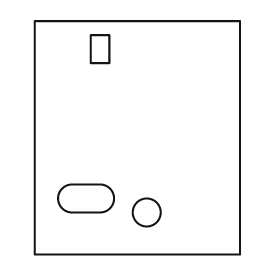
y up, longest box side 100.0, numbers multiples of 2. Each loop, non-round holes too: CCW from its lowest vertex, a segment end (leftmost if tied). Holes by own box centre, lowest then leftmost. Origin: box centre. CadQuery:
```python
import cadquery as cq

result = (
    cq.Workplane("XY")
    .moveTo(-44.0, -50.0)
    .lineTo(44.0, -50.0)
    .lineTo(44.0, 50.0)
    .lineTo(-44.0, 50.0)
    .close()
    .moveTo(4.0, -32.0)
    .circle(6.0)
    .moveTo(-28.0, -32.0)
    .lineTo(-16.0, -32.0)
    .threePointArc((-10.0, -26.0), (-16.0, -20.0))
    .lineTo(-28.0, -20.0)
    .threePointArc((-34.0, -26.0), (-28.0, -32.0))
    .close()
    .moveTo(-20.0, 32.0)
    .lineTo(-12.0, 32.0)
    .lineTo(-12.0, 44.0)
    .lineTo(-20.0, 44.0)
    .close()
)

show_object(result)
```